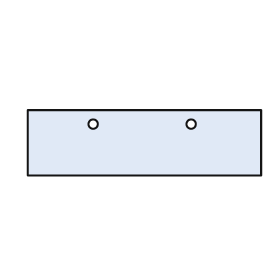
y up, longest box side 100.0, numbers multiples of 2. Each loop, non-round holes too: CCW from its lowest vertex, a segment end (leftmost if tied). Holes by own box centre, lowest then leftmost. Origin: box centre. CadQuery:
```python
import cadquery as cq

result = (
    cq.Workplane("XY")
    .moveTo(-50.0, -14.0)
    .lineTo(50.0, -14.0)
    .lineTo(50.0, 14.0)
    .lineTo(-50.0, 14.0)
    .close()
    .moveTo(-22.0, 8.0)
    .circle(2.0)
    .moveTo(20.0, 8.0)
    .circle(2.0)
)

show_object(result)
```